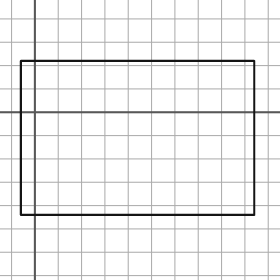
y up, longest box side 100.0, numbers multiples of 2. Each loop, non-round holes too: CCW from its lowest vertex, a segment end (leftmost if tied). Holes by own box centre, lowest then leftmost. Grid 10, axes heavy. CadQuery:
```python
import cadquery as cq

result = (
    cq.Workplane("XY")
    .moveTo(-6.0, -44.0)
    .lineTo(94.0, -44.0)
    .lineTo(94.0, 22.0)
    .lineTo(-6.0, 22.0)
    .close()
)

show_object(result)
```